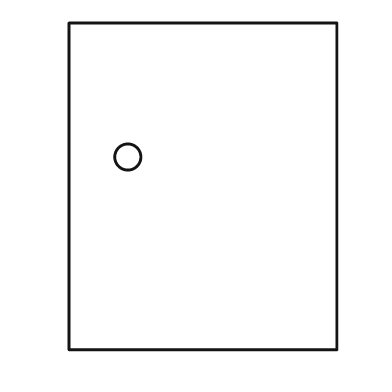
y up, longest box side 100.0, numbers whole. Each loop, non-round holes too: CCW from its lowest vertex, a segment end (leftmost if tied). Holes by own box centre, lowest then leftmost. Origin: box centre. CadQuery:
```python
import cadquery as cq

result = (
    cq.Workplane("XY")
    .moveTo(-41.0, -50.0)
    .lineTo(41.0, -50.0)
    .lineTo(41.0, 50.0)
    .lineTo(-41.0, 50.0)
    .close()
    .moveTo(-23.0, 9.0)
    .circle(4.0)
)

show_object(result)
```